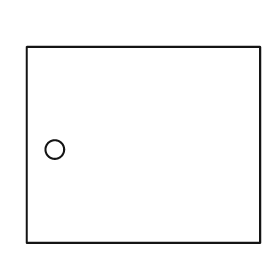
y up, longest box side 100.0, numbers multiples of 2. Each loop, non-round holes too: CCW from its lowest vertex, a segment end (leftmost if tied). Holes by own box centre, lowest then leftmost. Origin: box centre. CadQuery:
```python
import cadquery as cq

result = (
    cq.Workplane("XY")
    .moveTo(-50.0, -42.0)
    .lineTo(50.0, -42.0)
    .lineTo(50.0, 42.0)
    .lineTo(-50.0, 42.0)
    .close()
    .moveTo(-38.0, -2.0)
    .circle(4.0)
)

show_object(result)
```